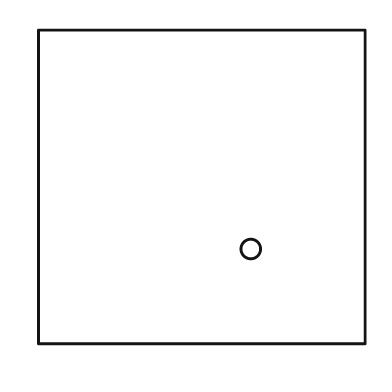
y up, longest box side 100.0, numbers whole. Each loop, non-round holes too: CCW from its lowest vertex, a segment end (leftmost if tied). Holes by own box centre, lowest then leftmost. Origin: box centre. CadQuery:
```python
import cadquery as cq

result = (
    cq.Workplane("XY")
    .moveTo(-50.0, -48.0)
    .lineTo(50.0, -48.0)
    .lineTo(50.0, 48.0)
    .lineTo(-50.0, 48.0)
    .close()
    .moveTo(15.0, -19.0)
    .circle(3.0)
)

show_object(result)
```